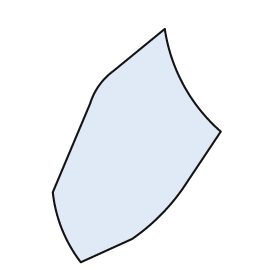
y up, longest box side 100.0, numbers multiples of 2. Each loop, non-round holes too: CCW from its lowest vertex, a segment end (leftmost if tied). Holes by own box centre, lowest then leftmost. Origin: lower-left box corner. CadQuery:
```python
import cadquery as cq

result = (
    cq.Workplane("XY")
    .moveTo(12.0, 0.0)
    .lineTo(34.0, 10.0)
    .threePointArc((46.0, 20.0), (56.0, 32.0))
    .lineTo(72.0, 56.0)
    .threePointArc((56.0, 76.0), (48.0, 100.0))
    .lineTo(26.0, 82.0)
    .threePointArc((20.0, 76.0), (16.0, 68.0))
    .lineTo(0.0, 30.0)
    .threePointArc((4.0, 14.0), (12.0, 0.0))
    .close()
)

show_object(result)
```